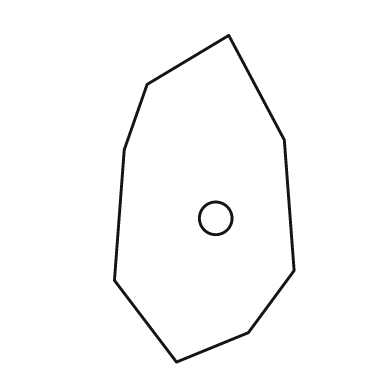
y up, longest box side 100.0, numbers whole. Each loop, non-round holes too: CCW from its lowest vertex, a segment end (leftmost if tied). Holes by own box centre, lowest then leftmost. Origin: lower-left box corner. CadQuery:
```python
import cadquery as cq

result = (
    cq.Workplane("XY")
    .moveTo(19.0, 0.0)
    .lineTo(41.0, 9.0)
    .lineTo(55.0, 28.0)
    .lineTo(52.0, 68.0)
    .lineTo(35.0, 100.0)
    .lineTo(10.0, 85.0)
    .lineTo(3.0, 65.0)
    .lineTo(0.0, 25.0)
    .close()
    .moveTo(31.0, 44.0)
    .circle(5.0)
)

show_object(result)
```